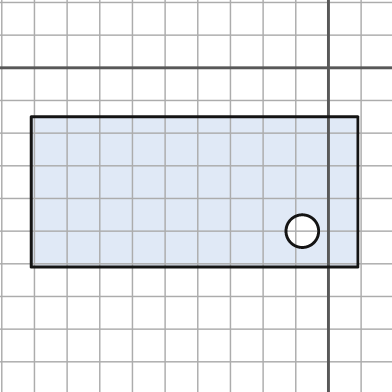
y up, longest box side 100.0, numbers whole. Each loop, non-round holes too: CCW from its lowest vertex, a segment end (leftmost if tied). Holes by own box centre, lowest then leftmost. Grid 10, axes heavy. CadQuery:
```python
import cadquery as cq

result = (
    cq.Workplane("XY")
    .moveTo(-91.0, -61.0)
    .lineTo(9.0, -61.0)
    .lineTo(9.0, -15.0)
    .lineTo(-91.0, -15.0)
    .close()
    .moveTo(-8.0, -50.0)
    .circle(5.0)
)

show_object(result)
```